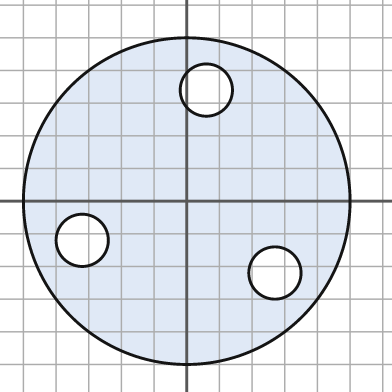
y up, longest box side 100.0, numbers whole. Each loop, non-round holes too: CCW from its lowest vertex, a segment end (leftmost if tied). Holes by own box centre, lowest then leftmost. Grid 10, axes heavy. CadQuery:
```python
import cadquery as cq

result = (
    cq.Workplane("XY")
    .moveTo(0.0, 0.0)
    .circle(50.0)
    .moveTo(27.0, -22.0)
    .circle(8.0)
    .moveTo(-32.0, -12.0)
    .circle(8.0)
    .moveTo(6.0, 34.0)
    .circle(8.0)
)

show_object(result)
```